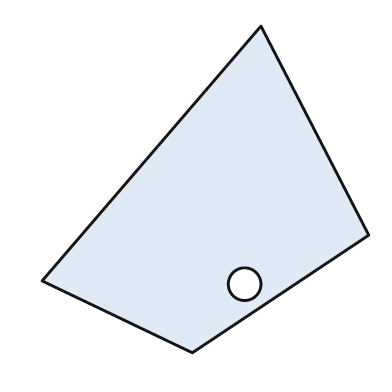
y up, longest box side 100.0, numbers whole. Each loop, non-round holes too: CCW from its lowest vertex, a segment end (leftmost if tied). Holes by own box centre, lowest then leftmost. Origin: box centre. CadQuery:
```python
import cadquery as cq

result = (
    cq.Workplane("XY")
    .moveTo(-4.0, -50.0)
    .lineTo(50.0, -14.0)
    .lineTo(17.0, 50.0)
    .lineTo(-50.0, -28.0)
    .close()
    .moveTo(12.0, -29.0)
    .circle(5.0)
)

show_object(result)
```